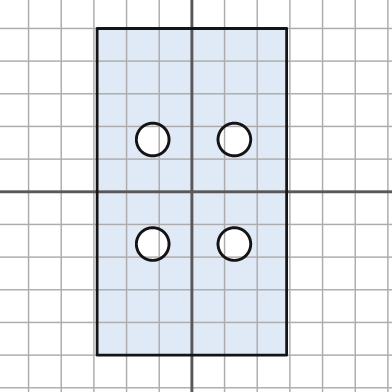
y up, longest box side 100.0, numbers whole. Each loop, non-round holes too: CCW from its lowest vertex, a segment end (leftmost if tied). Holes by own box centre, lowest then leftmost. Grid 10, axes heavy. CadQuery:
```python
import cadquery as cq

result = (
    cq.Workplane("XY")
    .moveTo(-29.0, -50.0)
    .lineTo(29.0, -50.0)
    .lineTo(29.0, 50.0)
    .lineTo(-29.0, 50.0)
    .close()
    .moveTo(-12.0, -16.0)
    .circle(5.0)
    .moveTo(13.0, -16.0)
    .circle(5.0)
    .moveTo(-12.0, 16.0)
    .circle(5.0)
    .moveTo(13.0, 16.0)
    .circle(5.0)
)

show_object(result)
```